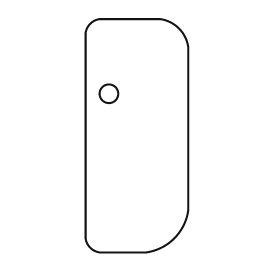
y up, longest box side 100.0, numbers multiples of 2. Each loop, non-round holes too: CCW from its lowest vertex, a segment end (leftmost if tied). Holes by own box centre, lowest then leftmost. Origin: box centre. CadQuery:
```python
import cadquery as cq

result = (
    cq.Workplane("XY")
    .moveTo(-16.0, -50.0)
    .lineTo(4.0, -50.0)
    .threePointArc((16.0, -44.0), (22.0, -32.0))
    .lineTo(22.0, 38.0)
    .threePointArc((18.0, 46.0), (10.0, 50.0))
    .lineTo(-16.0, 50.0)
    .threePointArc((-20.0, 48.0), (-22.0, 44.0))
    .lineTo(-22.0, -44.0)
    .threePointArc((-20.0, -48.0), (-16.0, -50.0))
    .close()
    .moveTo(-12.0, 18.0)
    .circle(4.0)
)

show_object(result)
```